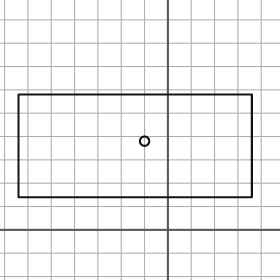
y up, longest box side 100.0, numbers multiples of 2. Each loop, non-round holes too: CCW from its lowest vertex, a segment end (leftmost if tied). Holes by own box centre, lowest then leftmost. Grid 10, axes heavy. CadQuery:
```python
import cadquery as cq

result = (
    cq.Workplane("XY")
    .moveTo(-64.0, 14.0)
    .lineTo(36.0, 14.0)
    .lineTo(36.0, 58.0)
    .lineTo(-64.0, 58.0)
    .close()
    .moveTo(-10.0, 38.0)
    .circle(2.0)
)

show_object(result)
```